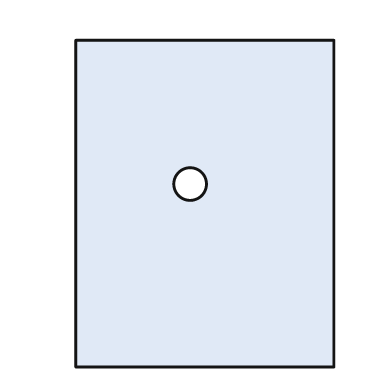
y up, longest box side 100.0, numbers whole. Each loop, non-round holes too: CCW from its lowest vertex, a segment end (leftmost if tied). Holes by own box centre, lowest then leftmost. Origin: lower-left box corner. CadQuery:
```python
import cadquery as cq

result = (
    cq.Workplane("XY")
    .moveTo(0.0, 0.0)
    .lineTo(79.0, 0.0)
    .lineTo(79.0, 100.0)
    .lineTo(0.0, 100.0)
    .close()
    .moveTo(35.0, 56.0)
    .circle(5.0)
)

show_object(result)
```